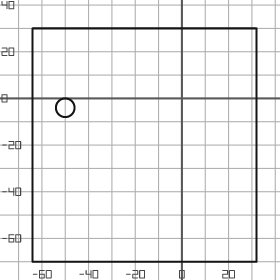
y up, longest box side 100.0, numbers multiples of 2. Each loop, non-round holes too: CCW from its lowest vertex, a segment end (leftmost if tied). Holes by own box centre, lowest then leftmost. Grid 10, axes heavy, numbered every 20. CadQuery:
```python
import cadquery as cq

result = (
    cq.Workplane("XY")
    .moveTo(-64.0, -70.0)
    .lineTo(32.0, -70.0)
    .lineTo(32.0, 30.0)
    .lineTo(-64.0, 30.0)
    .close()
    .moveTo(-50.0, -4.0)
    .circle(4.0)
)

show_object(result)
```